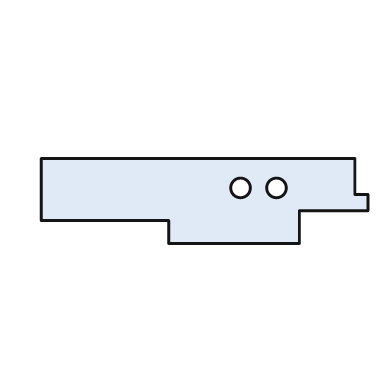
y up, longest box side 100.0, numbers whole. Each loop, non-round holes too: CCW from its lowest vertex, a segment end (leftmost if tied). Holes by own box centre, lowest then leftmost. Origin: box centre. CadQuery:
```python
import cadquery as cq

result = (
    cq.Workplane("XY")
    .moveTo(-11.0, -13.0)
    .lineTo(29.0, -13.0)
    .lineTo(29.0, -3.0)
    .lineTo(50.0, -3.0)
    .lineTo(50.0, 2.0)
    .lineTo(46.0, 2.0)
    .lineTo(46.0, 13.0)
    .lineTo(-50.0, 13.0)
    .lineTo(-50.0, -6.0)
    .lineTo(-11.0, -6.0)
    .close()
    .moveTo(11.0, 4.0)
    .circle(3.0)
    .moveTo(22.0, 4.0)
    .circle(3.0)
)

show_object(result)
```